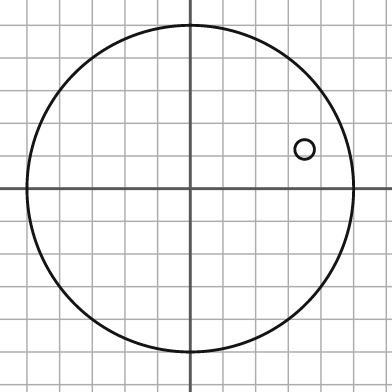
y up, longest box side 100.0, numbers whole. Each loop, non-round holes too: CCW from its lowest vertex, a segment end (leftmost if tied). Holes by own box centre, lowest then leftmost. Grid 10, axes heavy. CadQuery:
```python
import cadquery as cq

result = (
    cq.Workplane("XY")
    .moveTo(0.0, 0.0)
    .circle(50.0)
    .moveTo(35.0, 12.0)
    .circle(3.0)
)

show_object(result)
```